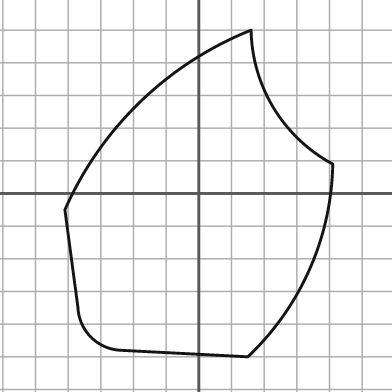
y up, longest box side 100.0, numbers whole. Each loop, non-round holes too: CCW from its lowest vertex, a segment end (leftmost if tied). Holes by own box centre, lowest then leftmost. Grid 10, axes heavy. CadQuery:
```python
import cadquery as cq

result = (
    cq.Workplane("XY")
    .moveTo(15.0, -50.0)
    .threePointArc((34.0, -23.0), (41.0, 9.0))
    .threePointArc((23.0, 26.0), (16.0, 50.0))
    .threePointArc((-18.0, 28.0), (-41.0, -5.0))
    .lineTo(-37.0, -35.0)
    .threePointArc((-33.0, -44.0), (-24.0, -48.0))
    .close()
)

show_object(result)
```